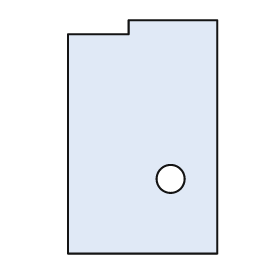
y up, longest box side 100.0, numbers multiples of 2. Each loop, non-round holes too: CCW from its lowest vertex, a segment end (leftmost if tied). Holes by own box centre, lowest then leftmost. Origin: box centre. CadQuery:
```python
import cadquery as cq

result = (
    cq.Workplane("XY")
    .moveTo(-32.0, -50.0)
    .lineTo(32.0, -50.0)
    .lineTo(32.0, 50.0)
    .lineTo(-6.0, 50.0)
    .lineTo(-6.0, 44.0)
    .lineTo(-32.0, 44.0)
    .close()
    .moveTo(12.0, -18.0)
    .circle(6.0)
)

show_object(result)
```